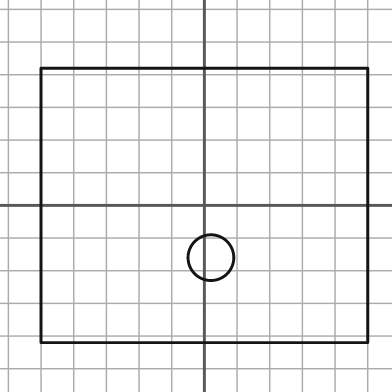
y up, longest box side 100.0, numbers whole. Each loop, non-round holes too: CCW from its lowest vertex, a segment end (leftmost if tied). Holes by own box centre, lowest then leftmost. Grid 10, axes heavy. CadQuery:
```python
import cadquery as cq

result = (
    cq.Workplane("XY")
    .moveTo(-50.0, -42.0)
    .lineTo(50.0, -42.0)
    .lineTo(50.0, 42.0)
    .lineTo(-50.0, 42.0)
    .close()
    .moveTo(2.0, -16.0)
    .circle(7.0)
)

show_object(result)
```